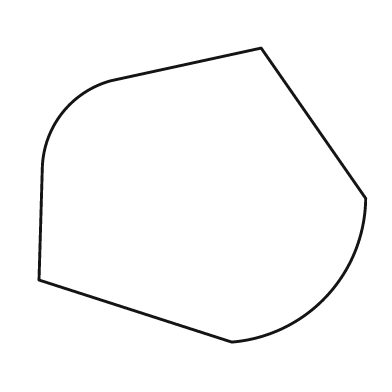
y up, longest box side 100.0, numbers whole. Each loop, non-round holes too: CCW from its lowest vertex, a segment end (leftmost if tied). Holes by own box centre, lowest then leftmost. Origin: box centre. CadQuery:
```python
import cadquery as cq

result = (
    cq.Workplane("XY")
    .moveTo(9.0, -45.0)
    .threePointArc((38.0, -31.0), (50.0, -1.0))
    .lineTo(18.0, 45.0)
    .lineTo(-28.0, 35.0)
    .threePointArc((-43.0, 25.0), (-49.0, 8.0))
    .lineTo(-50.0, -26.0)
    .close()
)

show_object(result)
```